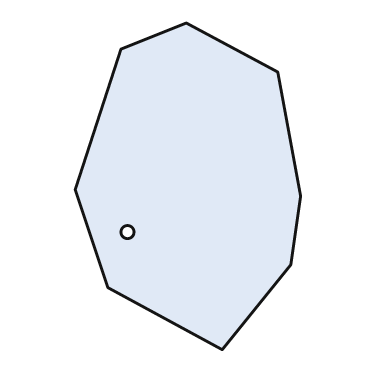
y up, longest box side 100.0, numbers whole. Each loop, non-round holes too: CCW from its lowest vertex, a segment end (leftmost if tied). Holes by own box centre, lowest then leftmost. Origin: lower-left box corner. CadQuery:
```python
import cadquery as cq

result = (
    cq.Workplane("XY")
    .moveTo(45.0, 0.0)
    .lineTo(66.0, 26.0)
    .lineTo(69.0, 47.0)
    .lineTo(62.0, 85.0)
    .lineTo(34.0, 100.0)
    .lineTo(14.0, 92.0)
    .lineTo(0.0, 49.0)
    .lineTo(10.0, 19.0)
    .close()
    .moveTo(16.0, 36.0)
    .circle(2.0)
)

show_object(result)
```